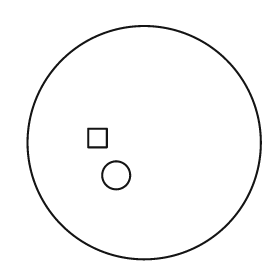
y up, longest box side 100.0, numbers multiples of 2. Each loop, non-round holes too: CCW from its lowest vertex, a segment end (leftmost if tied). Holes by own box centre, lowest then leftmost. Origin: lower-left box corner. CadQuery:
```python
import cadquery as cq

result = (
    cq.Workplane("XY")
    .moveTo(50.0, 50.0)
    .circle(50.0)
    .moveTo(38.0, 36.0)
    .circle(6.0)
    .moveTo(26.0, 48.0)
    .lineTo(34.0, 48.0)
    .lineTo(34.0, 56.0)
    .lineTo(26.0, 56.0)
    .close()
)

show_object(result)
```